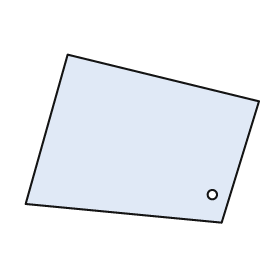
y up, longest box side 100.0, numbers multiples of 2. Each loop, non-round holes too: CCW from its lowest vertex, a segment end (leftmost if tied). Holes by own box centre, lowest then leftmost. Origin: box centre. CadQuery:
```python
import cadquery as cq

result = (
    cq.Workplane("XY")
    .moveTo(34.0, -36.0)
    .lineTo(50.0, 16.0)
    .lineTo(-32.0, 36.0)
    .lineTo(-50.0, -28.0)
    .close()
    .moveTo(30.0, -24.0)
    .circle(2.0)
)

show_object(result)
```